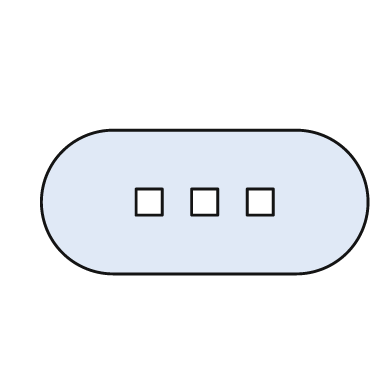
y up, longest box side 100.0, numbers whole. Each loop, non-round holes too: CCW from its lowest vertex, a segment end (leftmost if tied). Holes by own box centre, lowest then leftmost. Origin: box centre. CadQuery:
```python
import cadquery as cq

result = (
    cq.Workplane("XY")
    .moveTo(-28.0, -22.0)
    .lineTo(28.0, -22.0)
    .threePointArc((50.0, 0.0), (28.0, 22.0))
    .lineTo(-28.0, 22.0)
    .threePointArc((-50.0, 0.0), (-28.0, -22.0))
    .close()
    .moveTo(-21.0, -4.0)
    .lineTo(-13.0, -4.0)
    .lineTo(-13.0, 4.0)
    .lineTo(-21.0, 4.0)
    .close()
    .moveTo(-4.0, -4.0)
    .lineTo(4.0, -4.0)
    .lineTo(4.0, 4.0)
    .lineTo(-4.0, 4.0)
    .close()
    .moveTo(13.0, -4.0)
    .lineTo(21.0, -4.0)
    .lineTo(21.0, 4.0)
    .lineTo(13.0, 4.0)
    .close()
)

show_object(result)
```